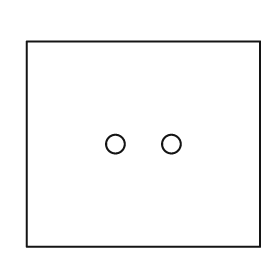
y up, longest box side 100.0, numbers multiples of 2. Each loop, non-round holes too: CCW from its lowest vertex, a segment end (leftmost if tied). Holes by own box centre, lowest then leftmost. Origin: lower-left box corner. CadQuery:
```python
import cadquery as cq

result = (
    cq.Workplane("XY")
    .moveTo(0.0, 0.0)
    .lineTo(100.0, 0.0)
    .lineTo(100.0, 88.0)
    .lineTo(0.0, 88.0)
    .close()
    .moveTo(38.0, 44.0)
    .circle(4.0)
    .moveTo(62.0, 44.0)
    .circle(4.0)
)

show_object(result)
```